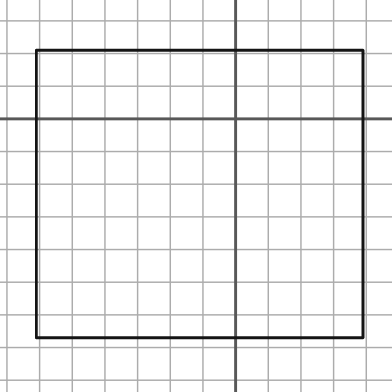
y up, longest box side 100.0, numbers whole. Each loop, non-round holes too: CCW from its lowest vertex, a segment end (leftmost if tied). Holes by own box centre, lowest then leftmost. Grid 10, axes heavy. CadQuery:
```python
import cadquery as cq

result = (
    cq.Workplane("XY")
    .moveTo(-61.0, -67.0)
    .lineTo(39.0, -67.0)
    .lineTo(39.0, 21.0)
    .lineTo(-61.0, 21.0)
    .close()
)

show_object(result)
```